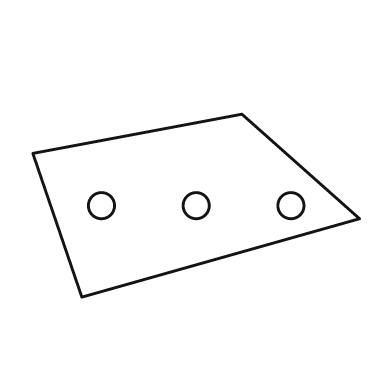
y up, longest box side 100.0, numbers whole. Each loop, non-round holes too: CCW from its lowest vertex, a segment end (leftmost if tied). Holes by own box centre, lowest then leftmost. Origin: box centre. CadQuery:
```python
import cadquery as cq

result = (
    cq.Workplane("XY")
    .moveTo(-35.0, -28.0)
    .lineTo(50.0, -4.0)
    .lineTo(14.0, 28.0)
    .lineTo(-50.0, 16.0)
    .close()
    .moveTo(-29.0, 0.0)
    .circle(4.0)
    .moveTo(0.0, 0.0)
    .circle(4.0)
    .moveTo(29.0, 0.0)
    .circle(4.0)
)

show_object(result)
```